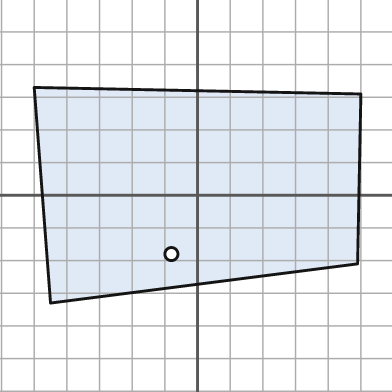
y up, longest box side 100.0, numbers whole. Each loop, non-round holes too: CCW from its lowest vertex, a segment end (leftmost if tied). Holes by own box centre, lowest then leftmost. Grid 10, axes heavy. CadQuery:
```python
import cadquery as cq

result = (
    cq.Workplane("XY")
    .moveTo(-45.0, -33.0)
    .lineTo(49.0, -21.0)
    .lineTo(50.0, 31.0)
    .lineTo(-50.0, 33.0)
    .close()
    .moveTo(-8.0, -18.0)
    .circle(2.0)
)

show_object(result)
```